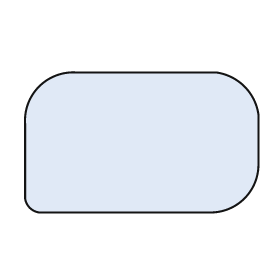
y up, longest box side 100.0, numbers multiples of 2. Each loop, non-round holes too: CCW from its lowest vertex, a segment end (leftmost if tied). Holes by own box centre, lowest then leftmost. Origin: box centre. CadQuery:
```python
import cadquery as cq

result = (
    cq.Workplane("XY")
    .moveTo(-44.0, -30.0)
    .lineTo(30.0, -30.0)
    .threePointArc((44.0, -24.0), (50.0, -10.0))
    .lineTo(50.0, 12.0)
    .threePointArc((44.0, 24.0), (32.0, 30.0))
    .lineTo(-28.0, 30.0)
    .threePointArc((-44.0, 24.0), (-50.0, 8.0))
    .lineTo(-50.0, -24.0)
    .threePointArc((-48.0, -28.0), (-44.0, -30.0))
    .close()
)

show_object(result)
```